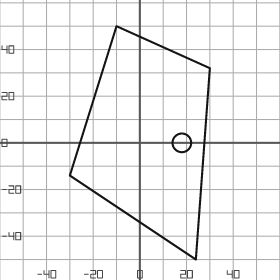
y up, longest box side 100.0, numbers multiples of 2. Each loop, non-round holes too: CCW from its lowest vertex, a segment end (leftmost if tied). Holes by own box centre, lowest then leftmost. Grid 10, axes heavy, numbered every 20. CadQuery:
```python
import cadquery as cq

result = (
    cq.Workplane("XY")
    .moveTo(24.0, -50.0)
    .lineTo(30.0, 32.0)
    .lineTo(-10.0, 50.0)
    .lineTo(-30.0, -14.0)
    .close()
    .moveTo(18.0, 0.0)
    .circle(4.0)
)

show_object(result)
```